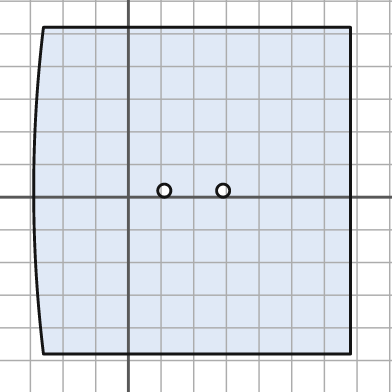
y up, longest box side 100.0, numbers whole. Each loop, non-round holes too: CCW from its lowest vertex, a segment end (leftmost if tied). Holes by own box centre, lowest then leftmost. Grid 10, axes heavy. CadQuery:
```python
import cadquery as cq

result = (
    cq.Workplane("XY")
    .moveTo(-26.0, -48.0)
    .lineTo(68.0, -48.0)
    .lineTo(68.0, 52.0)
    .lineTo(-26.0, 52.0)
    .threePointArc((-29.0, 2.0), (-26.0, -48.0))
    .close()
    .moveTo(11.0, 2.0)
    .circle(2.0)
    .moveTo(29.0, 2.0)
    .circle(2.0)
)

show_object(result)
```